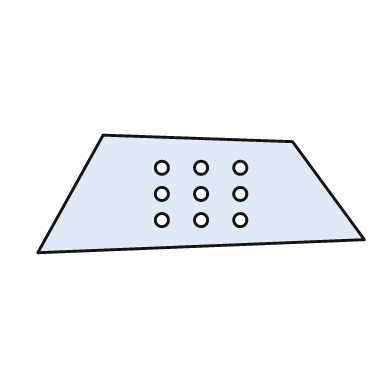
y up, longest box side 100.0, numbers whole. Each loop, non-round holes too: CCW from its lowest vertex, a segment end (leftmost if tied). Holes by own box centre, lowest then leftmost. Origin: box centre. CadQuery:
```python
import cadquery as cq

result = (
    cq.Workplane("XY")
    .moveTo(-50.0, -18.0)
    .lineTo(50.0, -14.0)
    .lineTo(28.0, 16.0)
    .lineTo(-30.0, 18.0)
    .close()
    .moveTo(-12.0, -8.0)
    .circle(2.0)
    .moveTo(0.0, -8.0)
    .circle(2.0)
    .moveTo(12.0, -8.0)
    .circle(2.0)
    .moveTo(-12.0, 0.0)
    .circle(2.0)
    .moveTo(0.0, 0.0)
    .circle(2.0)
    .moveTo(12.0, 0.0)
    .circle(2.0)
    .moveTo(-12.0, 8.0)
    .circle(2.0)
    .moveTo(0.0, 8.0)
    .circle(2.0)
    .moveTo(12.0, 8.0)
    .circle(2.0)
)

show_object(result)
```